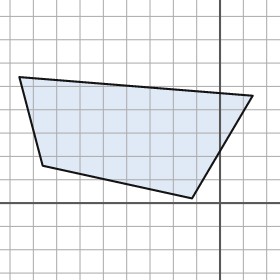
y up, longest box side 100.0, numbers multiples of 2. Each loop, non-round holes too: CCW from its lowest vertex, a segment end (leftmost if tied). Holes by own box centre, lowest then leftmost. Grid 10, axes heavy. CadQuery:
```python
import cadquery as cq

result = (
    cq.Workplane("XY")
    .moveTo(-12.0, 2.0)
    .lineTo(14.0, 46.0)
    .lineTo(-86.0, 54.0)
    .lineTo(-76.0, 16.0)
    .close()
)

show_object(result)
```